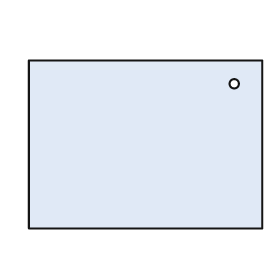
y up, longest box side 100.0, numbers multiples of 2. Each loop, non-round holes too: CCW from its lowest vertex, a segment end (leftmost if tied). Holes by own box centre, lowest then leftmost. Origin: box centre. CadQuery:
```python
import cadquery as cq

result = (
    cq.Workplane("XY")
    .moveTo(-50.0, -36.0)
    .lineTo(50.0, -36.0)
    .lineTo(50.0, 36.0)
    .lineTo(-50.0, 36.0)
    .close()
    .moveTo(38.0, 26.0)
    .circle(2.0)
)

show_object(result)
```